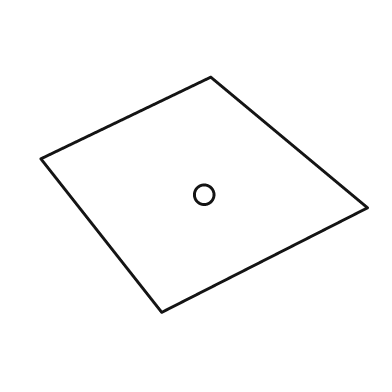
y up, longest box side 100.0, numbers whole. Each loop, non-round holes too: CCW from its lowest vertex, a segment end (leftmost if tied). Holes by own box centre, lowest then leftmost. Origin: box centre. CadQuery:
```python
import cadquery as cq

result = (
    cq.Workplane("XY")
    .moveTo(-13.0, -36.0)
    .lineTo(50.0, -4.0)
    .lineTo(2.0, 36.0)
    .lineTo(-50.0, 11.0)
    .close()
    .moveTo(0.0, 0.0)
    .circle(3.0)
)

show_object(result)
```